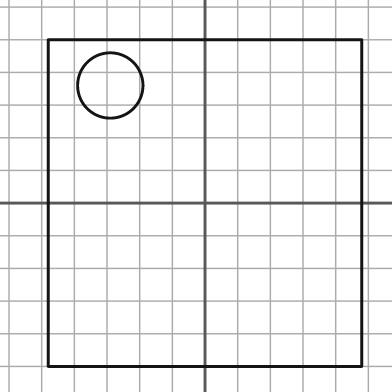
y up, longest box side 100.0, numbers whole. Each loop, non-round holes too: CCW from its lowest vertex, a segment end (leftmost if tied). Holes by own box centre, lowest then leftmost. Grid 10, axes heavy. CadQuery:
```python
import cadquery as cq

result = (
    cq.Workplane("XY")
    .moveTo(-48.0, -50.0)
    .lineTo(48.0, -50.0)
    .lineTo(48.0, 50.0)
    .lineTo(-48.0, 50.0)
    .close()
    .moveTo(-29.0, 36.0)
    .circle(10.0)
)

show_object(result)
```